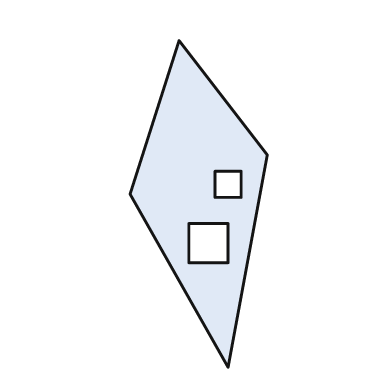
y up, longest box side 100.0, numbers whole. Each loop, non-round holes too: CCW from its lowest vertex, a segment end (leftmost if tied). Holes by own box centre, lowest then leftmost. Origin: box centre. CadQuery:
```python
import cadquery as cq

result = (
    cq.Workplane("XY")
    .moveTo(9.0, -50.0)
    .lineTo(21.0, 15.0)
    .lineTo(-6.0, 50.0)
    .lineTo(-21.0, 3.0)
    .close()
    .moveTo(-3.0, -18.0)
    .lineTo(9.0, -18.0)
    .lineTo(9.0, -6.0)
    .lineTo(-3.0, -6.0)
    .close()
    .moveTo(5.0, 2.0)
    .lineTo(13.0, 2.0)
    .lineTo(13.0, 10.0)
    .lineTo(5.0, 10.0)
    .close()
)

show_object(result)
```